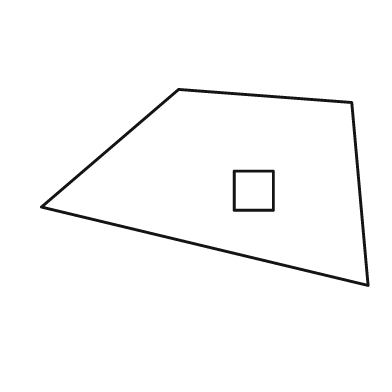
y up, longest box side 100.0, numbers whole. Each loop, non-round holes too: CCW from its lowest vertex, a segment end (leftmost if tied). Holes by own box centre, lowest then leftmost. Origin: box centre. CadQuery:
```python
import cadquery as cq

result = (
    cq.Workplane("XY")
    .moveTo(50.0, -30.0)
    .lineTo(45.0, 26.0)
    .lineTo(-8.0, 30.0)
    .lineTo(-50.0, -6.0)
    .close()
    .moveTo(9.0, -7.0)
    .lineTo(21.0, -7.0)
    .lineTo(21.0, 5.0)
    .lineTo(9.0, 5.0)
    .close()
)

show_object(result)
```